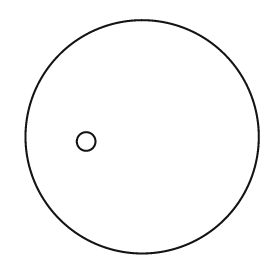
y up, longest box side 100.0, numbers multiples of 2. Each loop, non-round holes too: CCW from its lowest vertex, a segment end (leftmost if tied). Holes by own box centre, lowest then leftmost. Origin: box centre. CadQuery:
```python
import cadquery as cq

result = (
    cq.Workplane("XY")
    .moveTo(0.0, 0.0)
    .circle(50.0)
    .moveTo(-24.0, -2.0)
    .circle(4.0)
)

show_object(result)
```